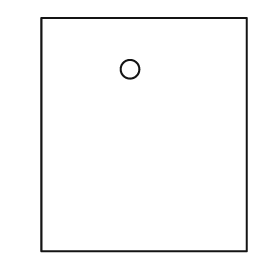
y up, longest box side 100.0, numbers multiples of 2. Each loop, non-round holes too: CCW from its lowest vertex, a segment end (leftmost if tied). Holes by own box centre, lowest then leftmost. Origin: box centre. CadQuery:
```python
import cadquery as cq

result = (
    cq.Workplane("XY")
    .moveTo(-44.0, -50.0)
    .lineTo(44.0, -50.0)
    .lineTo(44.0, 50.0)
    .lineTo(-44.0, 50.0)
    .close()
    .moveTo(-6.0, 28.0)
    .circle(4.0)
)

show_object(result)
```